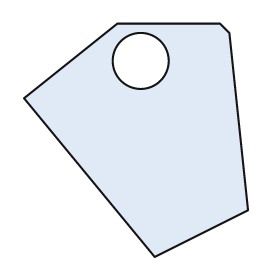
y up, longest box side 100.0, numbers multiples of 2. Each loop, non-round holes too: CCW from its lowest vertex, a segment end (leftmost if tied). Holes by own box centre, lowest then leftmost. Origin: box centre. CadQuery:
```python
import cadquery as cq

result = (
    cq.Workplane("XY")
    .moveTo(8.0, -50.0)
    .lineTo(48.0, -30.0)
    .lineTo(40.0, 46.0)
    .lineTo(36.0, 50.0)
    .lineTo(-8.0, 50.0)
    .lineTo(-48.0, 18.0)
    .close()
    .moveTo(2.0, 34.0)
    .circle(12.0)
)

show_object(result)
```